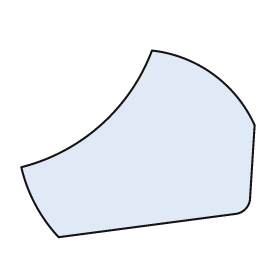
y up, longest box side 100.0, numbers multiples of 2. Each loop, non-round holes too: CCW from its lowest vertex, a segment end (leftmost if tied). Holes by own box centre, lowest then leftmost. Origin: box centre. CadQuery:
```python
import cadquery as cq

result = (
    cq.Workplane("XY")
    .moveTo(-34.0, -40.0)
    .lineTo(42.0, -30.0)
    .threePointArc((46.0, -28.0), (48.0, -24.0))
    .lineTo(50.0, 8.0)
    .threePointArc((32.0, 30.0), (6.0, 40.0))
    .threePointArc((-16.0, 8.0), (-50.0, -10.0))
    .threePointArc((-44.0, -26.0), (-34.0, -40.0))
    .close()
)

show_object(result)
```